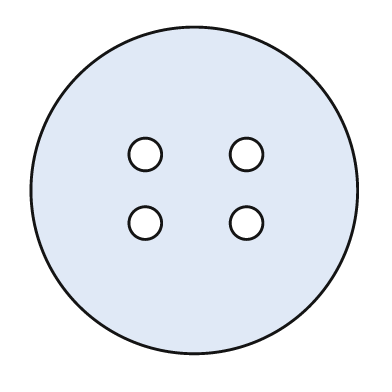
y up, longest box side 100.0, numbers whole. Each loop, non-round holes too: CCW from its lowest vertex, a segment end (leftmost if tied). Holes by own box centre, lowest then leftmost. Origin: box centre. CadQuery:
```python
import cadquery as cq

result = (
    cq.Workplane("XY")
    .moveTo(0.0, 0.0)
    .circle(50.0)
    .moveTo(-15.0, -10.0)
    .circle(5.0)
    .moveTo(16.0, -10.0)
    .circle(5.0)
    .moveTo(-15.0, 11.0)
    .circle(5.0)
    .moveTo(16.0, 11.0)
    .circle(5.0)
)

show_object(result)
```